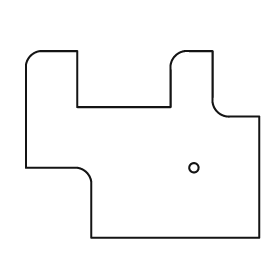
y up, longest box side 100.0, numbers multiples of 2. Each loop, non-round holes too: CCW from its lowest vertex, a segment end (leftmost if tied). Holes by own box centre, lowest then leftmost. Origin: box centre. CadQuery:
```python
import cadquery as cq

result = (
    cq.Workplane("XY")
    .moveTo(-22.0, -40.0)
    .lineTo(50.0, -40.0)
    .lineTo(50.0, 12.0)
    .lineTo(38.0, 12.0)
    .threePointArc((32.0, 14.0), (30.0, 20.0))
    .lineTo(30.0, 40.0)
    .lineTo(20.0, 40.0)
    .threePointArc((14.0, 38.0), (12.0, 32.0))
    .lineTo(12.0, 16.0)
    .lineTo(-28.0, 16.0)
    .lineTo(-28.0, 40.0)
    .lineTo(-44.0, 40.0)
    .threePointArc((-48.0, 38.0), (-50.0, 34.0))
    .lineTo(-50.0, -10.0)
    .lineTo(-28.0, -10.0)
    .threePointArc((-24.0, -12.0), (-22.0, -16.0))
    .close()
    .moveTo(22.0, -10.0)
    .circle(2.0)
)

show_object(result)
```